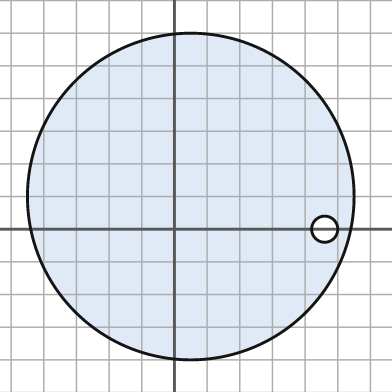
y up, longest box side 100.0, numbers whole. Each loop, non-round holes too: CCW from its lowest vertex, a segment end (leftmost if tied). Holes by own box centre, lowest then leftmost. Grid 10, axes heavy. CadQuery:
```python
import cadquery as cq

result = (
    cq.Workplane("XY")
    .moveTo(5.0, 10.0)
    .circle(50.0)
    .moveTo(46.0, 0.0)
    .circle(4.0)
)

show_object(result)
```